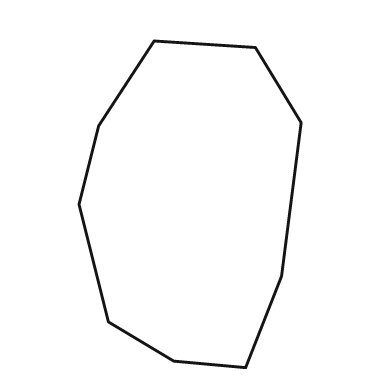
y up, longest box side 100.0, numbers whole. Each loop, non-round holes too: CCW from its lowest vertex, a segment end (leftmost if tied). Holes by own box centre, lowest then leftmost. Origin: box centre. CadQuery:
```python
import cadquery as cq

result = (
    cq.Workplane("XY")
    .moveTo(17.0, -50.0)
    .lineTo(28.0, -22.0)
    .lineTo(34.0, 25.0)
    .lineTo(20.0, 48.0)
    .lineTo(-11.0, 50.0)
    .lineTo(-28.0, 24.0)
    .lineTo(-34.0, 0.0)
    .lineTo(-25.0, -36.0)
    .lineTo(-5.0, -48.0)
    .close()
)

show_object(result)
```